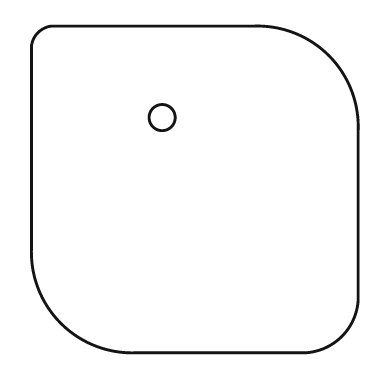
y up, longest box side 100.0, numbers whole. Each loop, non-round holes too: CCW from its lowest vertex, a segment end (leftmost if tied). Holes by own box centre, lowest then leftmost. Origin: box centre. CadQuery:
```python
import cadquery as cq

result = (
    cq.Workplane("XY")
    .moveTo(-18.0, -50.0)
    .lineTo(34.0, -50.0)
    .threePointArc((45.0, -45.0), (50.0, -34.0))
    .lineTo(50.0, 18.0)
    .threePointArc((41.0, 41.0), (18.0, 50.0))
    .lineTo(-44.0, 50.0)
    .threePointArc((-48.0, 48.0), (-50.0, 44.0))
    .lineTo(-50.0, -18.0)
    .threePointArc((-41.0, -41.0), (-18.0, -50.0))
    .close()
    .moveTo(-10.0, 22.0)
    .circle(4.0)
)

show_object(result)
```